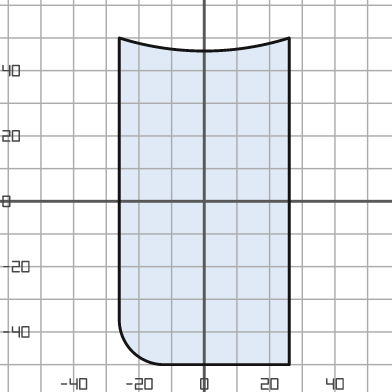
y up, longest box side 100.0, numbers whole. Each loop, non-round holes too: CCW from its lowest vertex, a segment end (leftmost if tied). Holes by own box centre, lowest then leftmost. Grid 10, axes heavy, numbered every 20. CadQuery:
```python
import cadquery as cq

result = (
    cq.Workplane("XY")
    .moveTo(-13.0, -50.0)
    .lineTo(26.0, -50.0)
    .lineTo(26.0, 50.0)
    .threePointArc((0.0, 46.0), (-26.0, 50.0))
    .lineTo(-26.0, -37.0)
    .threePointArc((-22.0, -46.0), (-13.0, -50.0))
    .close()
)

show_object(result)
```